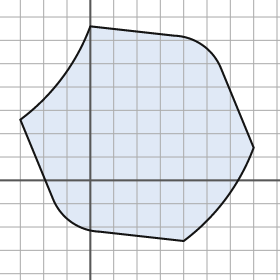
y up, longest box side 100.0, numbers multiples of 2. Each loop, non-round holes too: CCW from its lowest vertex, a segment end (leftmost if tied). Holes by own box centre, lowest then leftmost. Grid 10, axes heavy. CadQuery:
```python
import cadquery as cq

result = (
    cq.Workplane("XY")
    .moveTo(40.0, -26.0)
    .threePointArc((58.0, -8.0), (70.0, 14.0))
    .lineTo(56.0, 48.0)
    .threePointArc((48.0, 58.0), (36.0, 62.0))
    .lineTo(0.0, 66.0)
    .threePointArc((-12.0, 44.0), (-30.0, 26.0))
    .lineTo(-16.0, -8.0)
    .threePointArc((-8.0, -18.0), (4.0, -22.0))
    .close()
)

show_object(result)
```